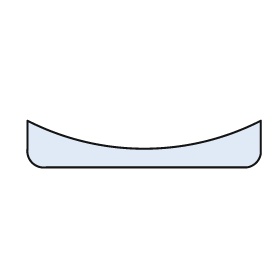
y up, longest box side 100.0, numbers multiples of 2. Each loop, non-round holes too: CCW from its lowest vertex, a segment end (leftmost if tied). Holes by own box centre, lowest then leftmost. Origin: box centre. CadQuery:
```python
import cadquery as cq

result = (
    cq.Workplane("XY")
    .moveTo(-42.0, -10.0)
    .lineTo(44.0, -10.0)
    .threePointArc((48.0, -8.0), (50.0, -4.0))
    .lineTo(50.0, 10.0)
    .threePointArc((0.0, -2.0), (-50.0, 10.0))
    .lineTo(-50.0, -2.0)
    .threePointArc((-48.0, -8.0), (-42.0, -10.0))
    .close()
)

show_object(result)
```